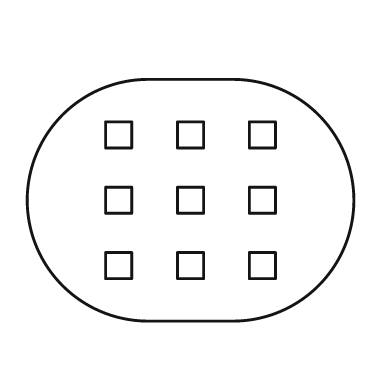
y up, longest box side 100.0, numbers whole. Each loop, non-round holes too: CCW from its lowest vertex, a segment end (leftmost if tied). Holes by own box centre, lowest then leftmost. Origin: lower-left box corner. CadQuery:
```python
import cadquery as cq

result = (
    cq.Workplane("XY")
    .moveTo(37.0, 0.0)
    .lineTo(63.0, 0.0)
    .threePointArc((100.0, 37.0), (63.0, 74.0))
    .lineTo(37.0, 74.0)
    .threePointArc((0.0, 37.0), (37.0, 0.0))
    .close()
    .moveTo(24.0, 13.0)
    .lineTo(32.0, 13.0)
    .lineTo(32.0, 21.0)
    .lineTo(24.0, 21.0)
    .close()
    .moveTo(46.0, 13.0)
    .lineTo(54.0, 13.0)
    .lineTo(54.0, 21.0)
    .lineTo(46.0, 21.0)
    .close()
    .moveTo(68.0, 13.0)
    .lineTo(76.0, 13.0)
    .lineTo(76.0, 21.0)
    .lineTo(68.0, 21.0)
    .close()
    .moveTo(24.0, 33.0)
    .lineTo(32.0, 33.0)
    .lineTo(32.0, 41.0)
    .lineTo(24.0, 41.0)
    .close()
    .moveTo(46.0, 33.0)
    .lineTo(54.0, 33.0)
    .lineTo(54.0, 41.0)
    .lineTo(46.0, 41.0)
    .close()
    .moveTo(68.0, 33.0)
    .lineTo(76.0, 33.0)
    .lineTo(76.0, 41.0)
    .lineTo(68.0, 41.0)
    .close()
    .moveTo(24.0, 53.0)
    .lineTo(32.0, 53.0)
    .lineTo(32.0, 61.0)
    .lineTo(24.0, 61.0)
    .close()
    .moveTo(46.0, 53.0)
    .lineTo(54.0, 53.0)
    .lineTo(54.0, 61.0)
    .lineTo(46.0, 61.0)
    .close()
    .moveTo(68.0, 53.0)
    .lineTo(76.0, 53.0)
    .lineTo(76.0, 61.0)
    .lineTo(68.0, 61.0)
    .close()
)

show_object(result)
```